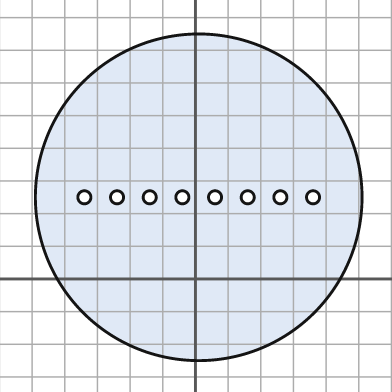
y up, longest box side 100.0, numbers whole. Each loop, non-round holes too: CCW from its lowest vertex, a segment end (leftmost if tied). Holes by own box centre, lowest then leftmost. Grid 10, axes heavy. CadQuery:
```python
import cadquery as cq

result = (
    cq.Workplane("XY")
    .moveTo(1.0, 25.0)
    .circle(50.0)
    .moveTo(-34.0, 25.0)
    .circle(2.0)
    .moveTo(-24.0, 25.0)
    .circle(2.0)
    .moveTo(-14.0, 25.0)
    .circle(2.0)
    .moveTo(-4.0, 25.0)
    .circle(2.0)
    .moveTo(6.0, 25.0)
    .circle(2.0)
    .moveTo(16.0, 25.0)
    .circle(2.0)
    .moveTo(26.0, 25.0)
    .circle(2.0)
    .moveTo(36.0, 25.0)
    .circle(2.0)
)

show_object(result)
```